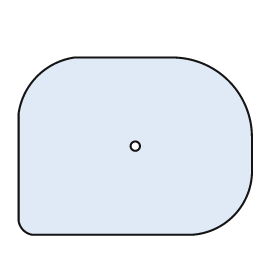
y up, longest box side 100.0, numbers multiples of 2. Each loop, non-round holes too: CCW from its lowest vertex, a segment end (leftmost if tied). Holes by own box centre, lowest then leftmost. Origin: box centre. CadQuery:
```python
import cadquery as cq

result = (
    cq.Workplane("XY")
    .moveTo(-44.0, -38.0)
    .lineTo(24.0, -38.0)
    .threePointArc((42.0, -30.0), (50.0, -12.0))
    .lineTo(50.0, 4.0)
    .threePointArc((40.0, 28.0), (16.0, 38.0))
    .lineTo(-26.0, 38.0)
    .threePointArc((-42.0, 30.0), (-50.0, 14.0))
    .lineTo(-50.0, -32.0)
    .threePointArc((-48.0, -36.0), (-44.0, -38.0))
    .close()
    .moveTo(0.0, 0.0)
    .circle(2.0)
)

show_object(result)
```